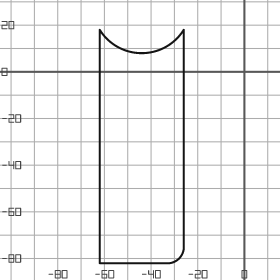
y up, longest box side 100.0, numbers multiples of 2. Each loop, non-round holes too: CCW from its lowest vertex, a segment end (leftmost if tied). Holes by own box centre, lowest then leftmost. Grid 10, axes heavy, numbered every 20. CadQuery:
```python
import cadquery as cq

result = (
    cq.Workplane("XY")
    .moveTo(-62.0, -82.0)
    .lineTo(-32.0, -82.0)
    .threePointArc((-28.0, -80.0), (-26.0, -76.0))
    .lineTo(-26.0, 18.0)
    .threePointArc((-44.0, 8.0), (-62.0, 18.0))
    .close()
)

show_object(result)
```